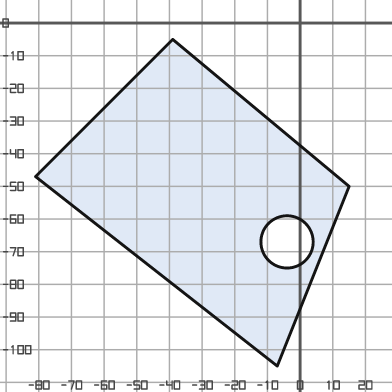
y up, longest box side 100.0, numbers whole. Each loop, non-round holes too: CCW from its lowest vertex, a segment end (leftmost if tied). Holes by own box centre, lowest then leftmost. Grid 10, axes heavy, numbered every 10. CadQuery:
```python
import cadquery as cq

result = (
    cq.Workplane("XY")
    .moveTo(-7.0, -105.0)
    .lineTo(15.0, -50.0)
    .lineTo(-39.0, -5.0)
    .lineTo(-81.0, -47.0)
    .close()
    .moveTo(-4.0, -67.0)
    .circle(8.0)
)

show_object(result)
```